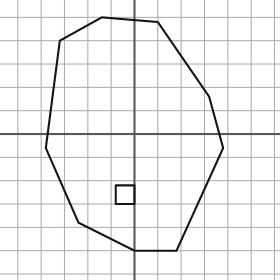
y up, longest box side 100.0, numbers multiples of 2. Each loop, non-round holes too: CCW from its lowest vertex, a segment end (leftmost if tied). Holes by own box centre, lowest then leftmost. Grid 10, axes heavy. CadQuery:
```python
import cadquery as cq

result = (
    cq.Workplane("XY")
    .moveTo(0.0, -50.0)
    .lineTo(18.0, -50.0)
    .lineTo(38.0, -6.0)
    .lineTo(32.0, 16.0)
    .lineTo(10.0, 48.0)
    .lineTo(-14.0, 50.0)
    .lineTo(-32.0, 40.0)
    .lineTo(-38.0, -6.0)
    .lineTo(-24.0, -38.0)
    .close()
    .moveTo(-8.0, -30.0)
    .lineTo(0.0, -30.0)
    .lineTo(0.0, -22.0)
    .lineTo(-8.0, -22.0)
    .close()
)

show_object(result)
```